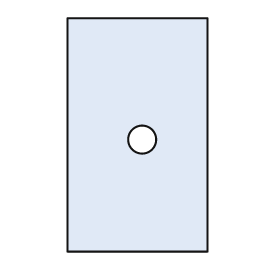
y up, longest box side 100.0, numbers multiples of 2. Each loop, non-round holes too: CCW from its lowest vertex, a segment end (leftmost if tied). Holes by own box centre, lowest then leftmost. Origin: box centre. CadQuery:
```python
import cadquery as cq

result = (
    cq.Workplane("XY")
    .moveTo(-30.0, -50.0)
    .lineTo(30.0, -50.0)
    .lineTo(30.0, 50.0)
    .lineTo(-30.0, 50.0)
    .close()
    .moveTo(2.0, -2.0)
    .circle(6.0)
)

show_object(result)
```